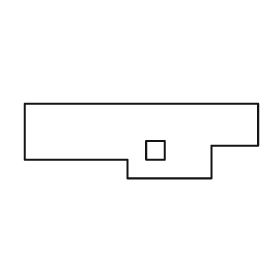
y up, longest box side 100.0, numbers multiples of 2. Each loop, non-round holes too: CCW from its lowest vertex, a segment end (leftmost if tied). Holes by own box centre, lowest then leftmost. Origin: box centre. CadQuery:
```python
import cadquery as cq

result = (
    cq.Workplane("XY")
    .moveTo(-6.0, -16.0)
    .lineTo(30.0, -16.0)
    .lineTo(30.0, -2.0)
    .lineTo(50.0, -2.0)
    .lineTo(50.0, 16.0)
    .lineTo(-50.0, 16.0)
    .lineTo(-50.0, -8.0)
    .lineTo(-6.0, -8.0)
    .close()
    .moveTo(2.0, -8.0)
    .lineTo(10.0, -8.0)
    .lineTo(10.0, 0.0)
    .lineTo(2.0, 0.0)
    .close()
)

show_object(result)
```